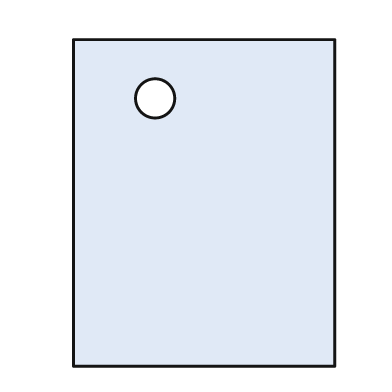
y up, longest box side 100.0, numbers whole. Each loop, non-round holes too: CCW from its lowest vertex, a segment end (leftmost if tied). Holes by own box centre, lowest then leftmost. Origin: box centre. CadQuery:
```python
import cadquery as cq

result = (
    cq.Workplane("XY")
    .moveTo(-40.0, -50.0)
    .lineTo(40.0, -50.0)
    .lineTo(40.0, 50.0)
    .lineTo(-40.0, 50.0)
    .close()
    .moveTo(-15.0, 32.0)
    .circle(6.0)
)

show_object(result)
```